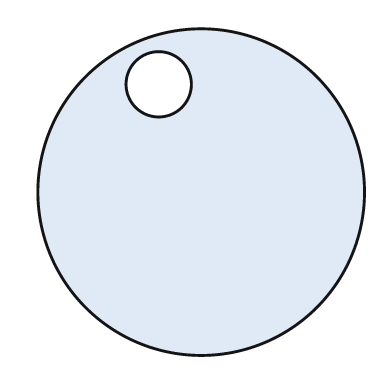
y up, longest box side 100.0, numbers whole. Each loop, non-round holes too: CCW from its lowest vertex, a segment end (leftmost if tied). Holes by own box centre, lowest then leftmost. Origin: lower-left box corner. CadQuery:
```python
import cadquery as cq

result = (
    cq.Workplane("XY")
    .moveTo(50.0, 50.0)
    .circle(50.0)
    .moveTo(37.0, 83.0)
    .circle(10.0)
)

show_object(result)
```